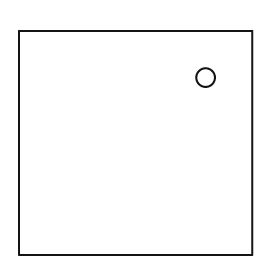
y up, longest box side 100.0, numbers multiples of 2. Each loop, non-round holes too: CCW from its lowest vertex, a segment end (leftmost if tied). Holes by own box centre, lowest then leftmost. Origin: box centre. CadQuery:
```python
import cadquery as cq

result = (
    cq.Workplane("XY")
    .moveTo(-50.0, -48.0)
    .lineTo(50.0, -48.0)
    .lineTo(50.0, 48.0)
    .lineTo(-50.0, 48.0)
    .close()
    .moveTo(30.0, 28.0)
    .circle(4.0)
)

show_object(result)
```